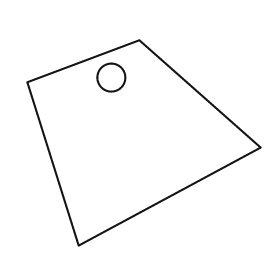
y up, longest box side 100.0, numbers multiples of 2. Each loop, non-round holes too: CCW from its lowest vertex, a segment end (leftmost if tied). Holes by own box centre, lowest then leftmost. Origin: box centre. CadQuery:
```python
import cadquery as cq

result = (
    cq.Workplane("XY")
    .moveTo(-28.0, -44.0)
    .lineTo(50.0, -2.0)
    .lineTo(-2.0, 44.0)
    .lineTo(-50.0, 26.0)
    .close()
    .moveTo(-14.0, 28.0)
    .circle(6.0)
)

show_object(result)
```